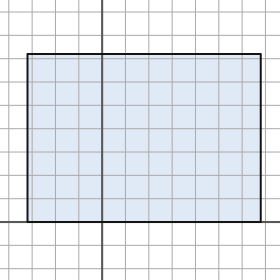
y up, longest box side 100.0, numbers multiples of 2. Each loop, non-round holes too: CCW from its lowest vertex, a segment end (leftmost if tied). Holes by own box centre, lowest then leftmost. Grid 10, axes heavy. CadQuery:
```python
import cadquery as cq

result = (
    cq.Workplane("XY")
    .moveTo(-32.0, 0.0)
    .lineTo(68.0, 0.0)
    .lineTo(68.0, 72.0)
    .lineTo(-32.0, 72.0)
    .close()
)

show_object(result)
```